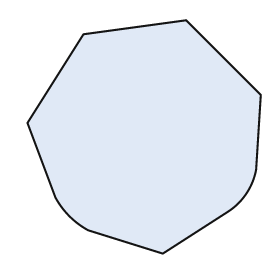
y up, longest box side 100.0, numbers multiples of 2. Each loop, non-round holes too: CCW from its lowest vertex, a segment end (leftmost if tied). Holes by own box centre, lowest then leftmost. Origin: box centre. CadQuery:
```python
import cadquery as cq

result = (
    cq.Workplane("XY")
    .moveTo(8.0, -50.0)
    .lineTo(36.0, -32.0)
    .threePointArc((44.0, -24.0), (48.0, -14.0))
    .lineTo(50.0, 18.0)
    .lineTo(18.0, 50.0)
    .lineTo(-26.0, 44.0)
    .lineTo(-50.0, 6.0)
    .lineTo(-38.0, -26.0)
    .threePointArc((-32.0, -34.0), (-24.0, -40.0))
    .close()
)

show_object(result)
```